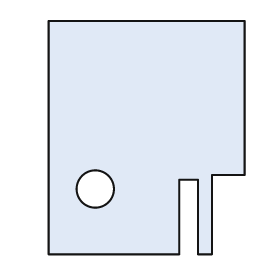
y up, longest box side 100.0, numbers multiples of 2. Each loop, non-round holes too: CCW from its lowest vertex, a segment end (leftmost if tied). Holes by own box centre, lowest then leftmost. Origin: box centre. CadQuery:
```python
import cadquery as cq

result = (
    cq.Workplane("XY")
    .moveTo(-42.0, -50.0)
    .lineTo(14.0, -50.0)
    .lineTo(14.0, -18.0)
    .lineTo(22.0, -18.0)
    .lineTo(22.0, -50.0)
    .lineTo(28.0, -50.0)
    .lineTo(28.0, -16.0)
    .lineTo(42.0, -16.0)
    .lineTo(42.0, 50.0)
    .lineTo(-42.0, 50.0)
    .close()
    .moveTo(-22.0, -22.0)
    .circle(8.0)
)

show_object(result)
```